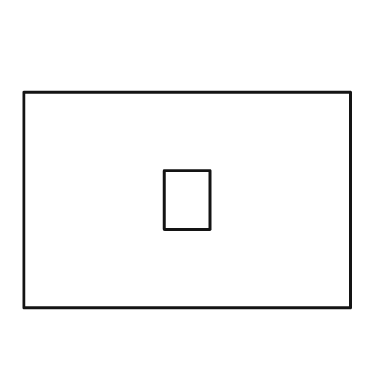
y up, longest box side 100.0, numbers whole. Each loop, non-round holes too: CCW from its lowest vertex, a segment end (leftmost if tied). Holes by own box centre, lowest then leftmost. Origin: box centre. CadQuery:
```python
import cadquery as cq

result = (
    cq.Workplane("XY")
    .moveTo(-50.0, -33.0)
    .lineTo(50.0, -33.0)
    .lineTo(50.0, 33.0)
    .lineTo(-50.0, 33.0)
    .close()
    .moveTo(-7.0, -9.0)
    .lineTo(7.0, -9.0)
    .lineTo(7.0, 9.0)
    .lineTo(-7.0, 9.0)
    .close()
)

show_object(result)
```